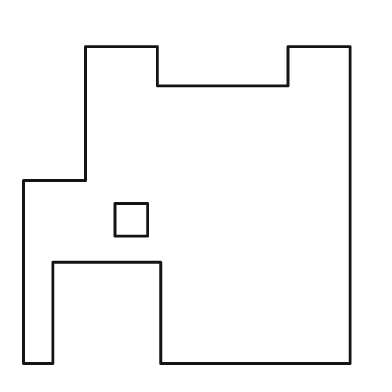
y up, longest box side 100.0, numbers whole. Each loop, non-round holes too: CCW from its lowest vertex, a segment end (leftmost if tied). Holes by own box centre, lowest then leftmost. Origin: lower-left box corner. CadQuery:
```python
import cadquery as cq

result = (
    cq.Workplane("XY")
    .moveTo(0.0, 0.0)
    .lineTo(9.0, 0.0)
    .lineTo(9.0, 31.0)
    .lineTo(42.0, 31.0)
    .lineTo(42.0, 0.0)
    .lineTo(100.0, 0.0)
    .lineTo(100.0, 97.0)
    .lineTo(81.0, 97.0)
    .lineTo(81.0, 85.0)
    .lineTo(41.0, 85.0)
    .lineTo(41.0, 97.0)
    .lineTo(19.0, 97.0)
    .lineTo(19.0, 56.0)
    .lineTo(0.0, 56.0)
    .close()
    .moveTo(28.0, 39.0)
    .lineTo(38.0, 39.0)
    .lineTo(38.0, 49.0)
    .lineTo(28.0, 49.0)
    .close()
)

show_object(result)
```